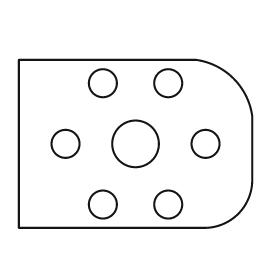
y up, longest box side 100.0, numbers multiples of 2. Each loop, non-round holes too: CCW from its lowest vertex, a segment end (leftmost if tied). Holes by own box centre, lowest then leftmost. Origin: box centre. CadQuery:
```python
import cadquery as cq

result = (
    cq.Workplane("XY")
    .moveTo(-50.0, -36.0)
    .lineTo(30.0, -36.0)
    .threePointArc((44.0, -30.0), (50.0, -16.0))
    .lineTo(50.0, 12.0)
    .threePointArc((42.0, 28.0), (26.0, 36.0))
    .lineTo(-50.0, 36.0)
    .close()
    .moveTo(-14.0, -26.0)
    .circle(6.0)
    .moveTo(14.0, -26.0)
    .circle(6.0)
    .moveTo(-30.0, 0.0)
    .circle(6.0)
    .moveTo(0.0, 0.0)
    .circle(10.0)
    .moveTo(30.0, 0.0)
    .circle(6.0)
    .moveTo(-14.0, 26.0)
    .circle(6.0)
    .moveTo(14.0, 26.0)
    .circle(6.0)
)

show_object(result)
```